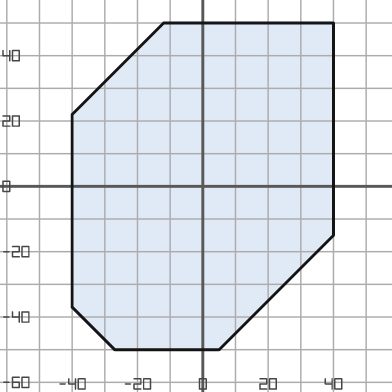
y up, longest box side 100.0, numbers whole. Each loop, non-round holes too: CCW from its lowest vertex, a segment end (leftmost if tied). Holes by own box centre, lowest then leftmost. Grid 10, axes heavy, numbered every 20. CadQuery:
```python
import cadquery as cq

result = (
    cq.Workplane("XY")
    .moveTo(-27.0, -50.0)
    .lineTo(5.0, -50.0)
    .lineTo(40.0, -15.0)
    .lineTo(40.0, 50.0)
    .lineTo(-12.0, 50.0)
    .lineTo(-40.0, 22.0)
    .lineTo(-40.0, -37.0)
    .close()
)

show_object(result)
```